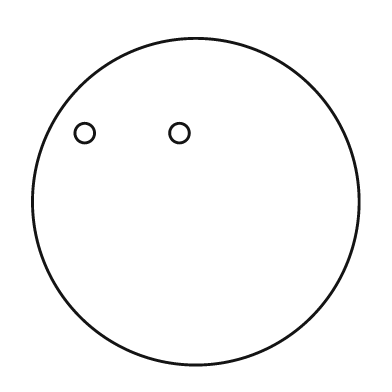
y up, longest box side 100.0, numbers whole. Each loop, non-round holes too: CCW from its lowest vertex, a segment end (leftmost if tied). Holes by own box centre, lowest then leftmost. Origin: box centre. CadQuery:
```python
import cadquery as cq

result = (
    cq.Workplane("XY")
    .moveTo(0.0, 0.0)
    .circle(50.0)
    .moveTo(-34.0, 21.0)
    .circle(3.0)
    .moveTo(-5.0, 21.0)
    .circle(3.0)
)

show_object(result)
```